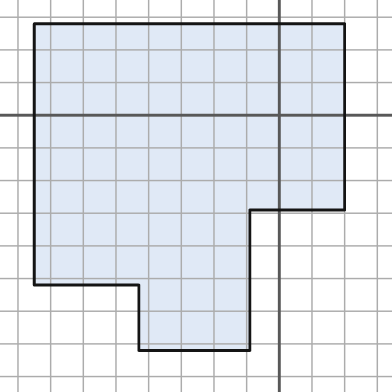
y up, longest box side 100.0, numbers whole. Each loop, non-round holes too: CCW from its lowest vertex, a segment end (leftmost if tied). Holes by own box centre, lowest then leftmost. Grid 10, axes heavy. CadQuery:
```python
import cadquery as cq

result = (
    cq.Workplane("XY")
    .moveTo(-43.0, -72.0)
    .lineTo(-9.0, -72.0)
    .lineTo(-9.0, -29.0)
    .lineTo(20.0, -29.0)
    .lineTo(20.0, 28.0)
    .lineTo(-75.0, 28.0)
    .lineTo(-75.0, -52.0)
    .lineTo(-43.0, -52.0)
    .close()
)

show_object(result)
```